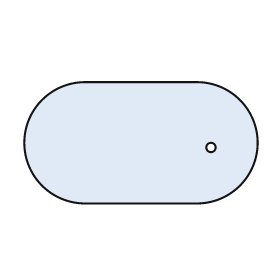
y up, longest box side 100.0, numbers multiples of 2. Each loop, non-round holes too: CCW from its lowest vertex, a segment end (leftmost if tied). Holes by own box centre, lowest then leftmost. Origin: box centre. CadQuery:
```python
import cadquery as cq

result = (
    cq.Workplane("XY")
    .moveTo(-24.0, -26.0)
    .lineTo(24.0, -26.0)
    .threePointArc((50.0, 0.0), (24.0, 26.0))
    .lineTo(-24.0, 26.0)
    .threePointArc((-50.0, 0.0), (-24.0, -26.0))
    .close()
    .moveTo(30.0, -2.0)
    .circle(2.0)
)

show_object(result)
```